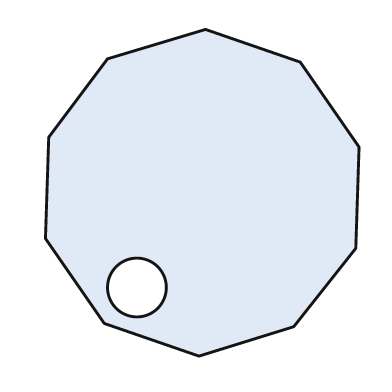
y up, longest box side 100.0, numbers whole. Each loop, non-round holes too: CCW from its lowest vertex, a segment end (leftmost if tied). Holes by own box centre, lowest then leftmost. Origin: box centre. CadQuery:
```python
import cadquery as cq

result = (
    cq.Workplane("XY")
    .moveTo(-1.0, -50.0)
    .lineTo(28.0, -41.0)
    .lineTo(47.0, -17.0)
    .lineTo(48.0, 14.0)
    .lineTo(30.0, 40.0)
    .lineTo(1.0, 50.0)
    .lineTo(-29.0, 41.0)
    .lineTo(-47.0, 17.0)
    .lineTo(-48.0, -14.0)
    .lineTo(-30.0, -40.0)
    .close()
    .moveTo(-20.0, -29.0)
    .circle(9.0)
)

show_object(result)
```